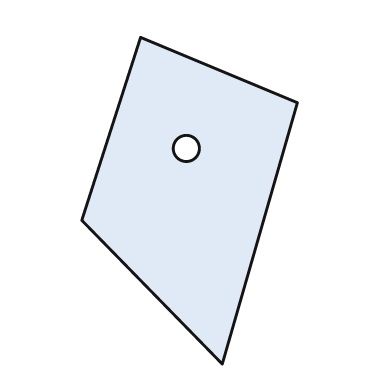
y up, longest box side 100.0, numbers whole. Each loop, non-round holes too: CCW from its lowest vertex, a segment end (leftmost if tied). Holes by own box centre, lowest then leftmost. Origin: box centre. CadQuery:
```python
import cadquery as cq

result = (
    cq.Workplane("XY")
    .moveTo(10.0, -50.0)
    .lineTo(33.0, 30.0)
    .lineTo(-15.0, 50.0)
    .lineTo(-33.0, -6.0)
    .close()
    .moveTo(-1.0, 16.0)
    .circle(4.0)
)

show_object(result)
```